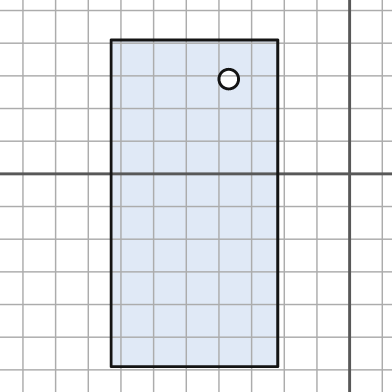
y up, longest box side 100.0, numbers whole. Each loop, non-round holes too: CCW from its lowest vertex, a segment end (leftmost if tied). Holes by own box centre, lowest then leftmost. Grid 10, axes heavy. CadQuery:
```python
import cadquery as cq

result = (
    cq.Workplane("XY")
    .moveTo(-73.0, -59.0)
    .lineTo(-22.0, -59.0)
    .lineTo(-22.0, 41.0)
    .lineTo(-73.0, 41.0)
    .close()
    .moveTo(-37.0, 29.0)
    .circle(3.0)
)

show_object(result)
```